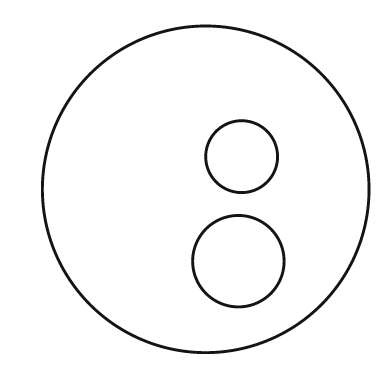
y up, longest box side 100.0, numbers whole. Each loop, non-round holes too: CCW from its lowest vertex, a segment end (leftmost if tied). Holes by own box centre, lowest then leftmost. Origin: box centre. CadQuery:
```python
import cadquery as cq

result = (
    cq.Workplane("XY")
    .moveTo(0.0, 0.0)
    .circle(50.0)
    .moveTo(10.0, -22.0)
    .circle(14.0)
    .moveTo(11.0, 10.0)
    .circle(11.0)
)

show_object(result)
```